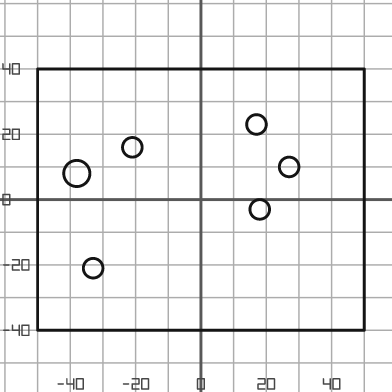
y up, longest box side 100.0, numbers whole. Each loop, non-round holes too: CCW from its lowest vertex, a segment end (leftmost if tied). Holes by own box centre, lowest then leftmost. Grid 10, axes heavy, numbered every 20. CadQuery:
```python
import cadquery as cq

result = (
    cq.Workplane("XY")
    .moveTo(-50.0, -40.0)
    .lineTo(50.0, -40.0)
    .lineTo(50.0, 40.0)
    .lineTo(-50.0, 40.0)
    .close()
    .moveTo(-33.0, -21.0)
    .circle(3.0)
    .moveTo(18.0, -3.0)
    .circle(3.0)
    .moveTo(-38.0, 8.0)
    .circle(4.0)
    .moveTo(27.0, 10.0)
    .circle(3.0)
    .moveTo(-21.0, 16.0)
    .circle(3.0)
    .moveTo(17.0, 23.0)
    .circle(3.0)
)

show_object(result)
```